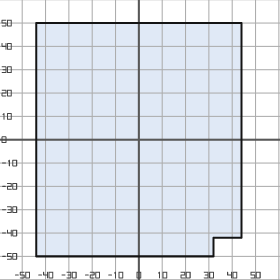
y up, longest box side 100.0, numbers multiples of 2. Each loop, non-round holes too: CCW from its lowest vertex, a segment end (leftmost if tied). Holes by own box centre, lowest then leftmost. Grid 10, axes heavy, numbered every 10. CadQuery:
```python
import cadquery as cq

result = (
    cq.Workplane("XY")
    .moveTo(-44.0, -50.0)
    .lineTo(32.0, -50.0)
    .lineTo(32.0, -42.0)
    .lineTo(44.0, -42.0)
    .lineTo(44.0, 50.0)
    .lineTo(-44.0, 50.0)
    .close()
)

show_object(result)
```